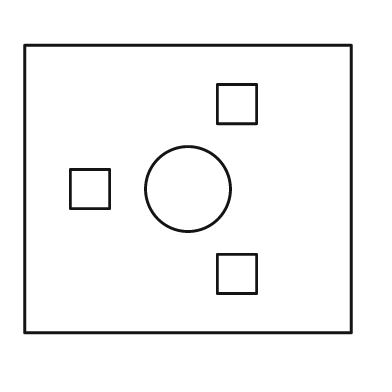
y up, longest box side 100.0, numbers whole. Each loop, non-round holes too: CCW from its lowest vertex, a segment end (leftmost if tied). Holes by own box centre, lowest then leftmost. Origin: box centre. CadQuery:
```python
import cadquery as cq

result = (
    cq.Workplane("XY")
    .moveTo(-50.0, -44.0)
    .lineTo(50.0, -44.0)
    .lineTo(50.0, 44.0)
    .lineTo(-50.0, 44.0)
    .close()
    .moveTo(9.0, -32.0)
    .lineTo(21.0, -32.0)
    .lineTo(21.0, -20.0)
    .lineTo(9.0, -20.0)
    .close()
    .moveTo(-36.0, -6.0)
    .lineTo(-24.0, -6.0)
    .lineTo(-24.0, 6.0)
    .lineTo(-36.0, 6.0)
    .close()
    .moveTo(0.0, 0.0)
    .circle(13.0)
    .moveTo(9.0, 20.0)
    .lineTo(21.0, 20.0)
    .lineTo(21.0, 32.0)
    .lineTo(9.0, 32.0)
    .close()
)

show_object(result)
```